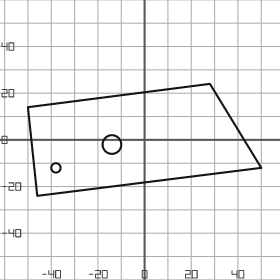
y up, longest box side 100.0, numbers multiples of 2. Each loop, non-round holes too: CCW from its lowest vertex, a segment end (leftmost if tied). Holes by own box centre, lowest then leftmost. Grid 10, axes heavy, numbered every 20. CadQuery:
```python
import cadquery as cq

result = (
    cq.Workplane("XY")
    .moveTo(-46.0, -24.0)
    .lineTo(50.0, -12.0)
    .lineTo(28.0, 24.0)
    .lineTo(-50.0, 14.0)
    .close()
    .moveTo(-38.0, -12.0)
    .circle(2.0)
    .moveTo(-14.0, -2.0)
    .circle(4.0)
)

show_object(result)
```